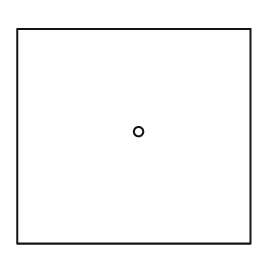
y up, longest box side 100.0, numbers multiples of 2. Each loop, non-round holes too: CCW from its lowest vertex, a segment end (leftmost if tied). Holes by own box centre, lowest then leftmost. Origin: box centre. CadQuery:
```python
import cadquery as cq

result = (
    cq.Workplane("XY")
    .moveTo(-50.0, -46.0)
    .lineTo(50.0, -46.0)
    .lineTo(50.0, 46.0)
    .lineTo(-50.0, 46.0)
    .close()
    .moveTo(2.0, 2.0)
    .circle(2.0)
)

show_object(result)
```